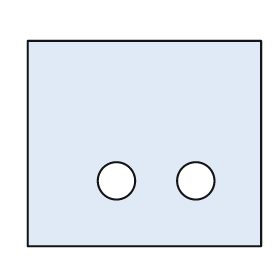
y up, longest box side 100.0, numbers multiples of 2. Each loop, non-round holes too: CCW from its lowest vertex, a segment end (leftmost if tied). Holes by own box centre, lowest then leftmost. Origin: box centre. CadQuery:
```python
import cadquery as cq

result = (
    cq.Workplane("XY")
    .moveTo(-50.0, -44.0)
    .lineTo(50.0, -44.0)
    .lineTo(50.0, 44.0)
    .lineTo(-50.0, 44.0)
    .close()
    .moveTo(-12.0, -16.0)
    .circle(8.0)
    .moveTo(22.0, -16.0)
    .circle(8.0)
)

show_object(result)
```